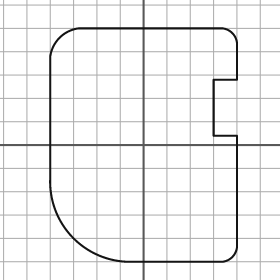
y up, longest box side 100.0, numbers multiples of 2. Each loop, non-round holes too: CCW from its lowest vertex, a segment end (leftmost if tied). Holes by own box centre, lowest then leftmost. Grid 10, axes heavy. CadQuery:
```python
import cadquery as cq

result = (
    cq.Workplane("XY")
    .moveTo(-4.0, -50.0)
    .lineTo(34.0, -50.0)
    .threePointArc((38.0, -48.0), (40.0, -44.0))
    .lineTo(40.0, 4.0)
    .lineTo(30.0, 4.0)
    .lineTo(30.0, 28.0)
    .lineTo(40.0, 28.0)
    .lineTo(40.0, 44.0)
    .threePointArc((38.0, 48.0), (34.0, 50.0))
    .lineTo(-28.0, 50.0)
    .threePointArc((-36.0, 46.0), (-40.0, 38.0))
    .lineTo(-40.0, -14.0)
    .threePointArc((-30.0, -40.0), (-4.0, -50.0))
    .close()
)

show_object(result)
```